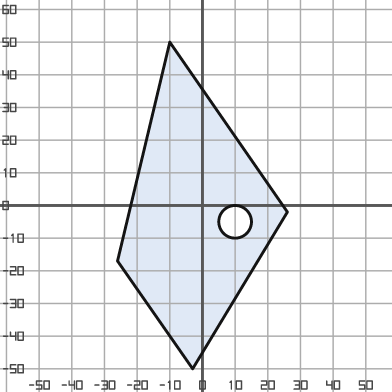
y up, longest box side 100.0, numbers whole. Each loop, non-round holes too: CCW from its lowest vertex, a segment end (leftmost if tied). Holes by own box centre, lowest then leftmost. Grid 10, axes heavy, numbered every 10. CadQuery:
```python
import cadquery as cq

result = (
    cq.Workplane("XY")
    .moveTo(-3.0, -50.0)
    .lineTo(26.0, -2.0)
    .lineTo(-10.0, 50.0)
    .lineTo(-26.0, -17.0)
    .close()
    .moveTo(10.0, -5.0)
    .circle(5.0)
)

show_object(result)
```